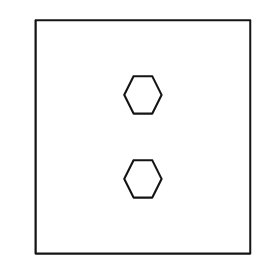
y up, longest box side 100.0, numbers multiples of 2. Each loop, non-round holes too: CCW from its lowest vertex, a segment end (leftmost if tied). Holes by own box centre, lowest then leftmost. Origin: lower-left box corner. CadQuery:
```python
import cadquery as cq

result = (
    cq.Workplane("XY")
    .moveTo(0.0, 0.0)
    .lineTo(92.0, 0.0)
    .lineTo(92.0, 100.0)
    .lineTo(0.0, 100.0)
    .close()
    .moveTo(42.0, 24.0)
    .lineTo(50.0, 24.0)
    .lineTo(54.0, 32.0)
    .lineTo(50.0, 40.0)
    .lineTo(42.0, 40.0)
    .lineTo(38.0, 32.0)
    .close()
    .moveTo(42.0, 60.0)
    .lineTo(50.0, 60.0)
    .lineTo(54.0, 68.0)
    .lineTo(50.0, 76.0)
    .lineTo(42.0, 76.0)
    .lineTo(38.0, 68.0)
    .close()
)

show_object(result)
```